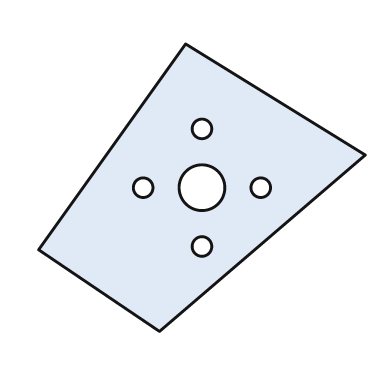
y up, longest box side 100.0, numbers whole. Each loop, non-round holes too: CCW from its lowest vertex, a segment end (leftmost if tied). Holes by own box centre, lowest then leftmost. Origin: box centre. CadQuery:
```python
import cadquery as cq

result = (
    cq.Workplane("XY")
    .moveTo(-13.0, -44.0)
    .lineTo(50.0, 10.0)
    .lineTo(-5.0, 44.0)
    .lineTo(-50.0, -19.0)
    .close()
    .moveTo(0.0, -18.0)
    .circle(3.0)
    .moveTo(-18.0, 0.0)
    .circle(3.0)
    .moveTo(0.0, 0.0)
    .circle(7.0)
    .moveTo(18.0, 0.0)
    .circle(3.0)
    .moveTo(0.0, 18.0)
    .circle(3.0)
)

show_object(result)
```